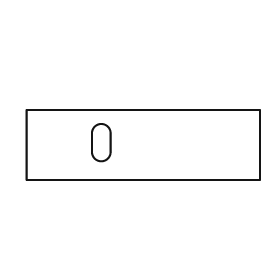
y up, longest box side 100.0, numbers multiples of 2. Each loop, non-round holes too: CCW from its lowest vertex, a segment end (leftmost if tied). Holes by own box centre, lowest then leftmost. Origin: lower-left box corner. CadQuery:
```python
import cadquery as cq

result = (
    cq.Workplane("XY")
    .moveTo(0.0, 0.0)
    .lineTo(100.0, 0.0)
    .lineTo(100.0, 30.0)
    .lineTo(0.0, 30.0)
    .close()
    .moveTo(28.0, 12.0)
    .threePointArc((32.0, 8.0), (36.0, 12.0))
    .lineTo(36.0, 20.0)
    .threePointArc((32.0, 24.0), (28.0, 20.0))
    .close()
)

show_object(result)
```